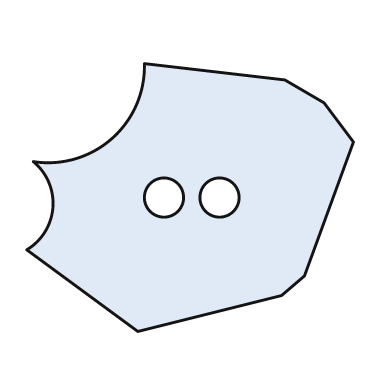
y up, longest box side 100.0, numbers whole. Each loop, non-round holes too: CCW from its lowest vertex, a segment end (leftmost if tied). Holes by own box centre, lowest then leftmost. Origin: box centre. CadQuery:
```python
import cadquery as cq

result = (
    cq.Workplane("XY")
    .moveTo(-16.0, -41.0)
    .lineTo(28.0, -30.0)
    .lineTo(35.0, -24.0)
    .lineTo(50.0, 17.0)
    .lineTo(41.0, 29.0)
    .lineTo(29.0, 36.0)
    .lineTo(-14.0, 41.0)
    .threePointArc((-24.0, 18.0), (-48.0, 11.0))
    .threePointArc((-42.0, -3.0), (-50.0, -16.0))
    .close()
    .moveTo(-8.0, 0.0)
    .circle(6.0)
    .moveTo(9.0, 0.0)
    .circle(6.0)
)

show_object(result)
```